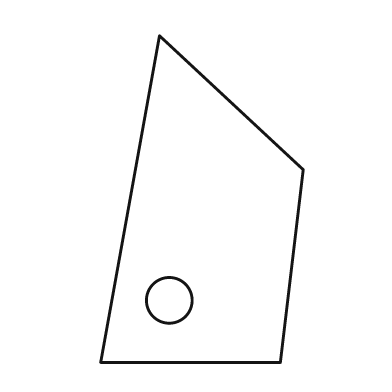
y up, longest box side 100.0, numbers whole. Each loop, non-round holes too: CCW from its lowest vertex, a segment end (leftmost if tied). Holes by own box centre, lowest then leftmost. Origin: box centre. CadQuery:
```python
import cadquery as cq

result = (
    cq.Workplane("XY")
    .moveTo(-31.0, -50.0)
    .lineTo(24.0, -50.0)
    .lineTo(31.0, 9.0)
    .lineTo(-13.0, 50.0)
    .close()
    .moveTo(-10.0, -31.0)
    .circle(7.0)
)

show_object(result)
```